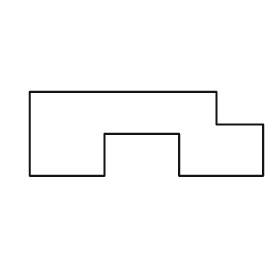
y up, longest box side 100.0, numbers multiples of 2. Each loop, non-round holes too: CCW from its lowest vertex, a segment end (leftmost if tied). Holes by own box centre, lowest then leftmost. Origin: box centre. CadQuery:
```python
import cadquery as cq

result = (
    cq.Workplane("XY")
    .moveTo(-50.0, -18.0)
    .lineTo(-18.0, -18.0)
    .lineTo(-18.0, 0.0)
    .lineTo(14.0, 0.0)
    .lineTo(14.0, -18.0)
    .lineTo(50.0, -18.0)
    .lineTo(50.0, 4.0)
    .lineTo(30.0, 4.0)
    .lineTo(30.0, 18.0)
    .lineTo(-50.0, 18.0)
    .close()
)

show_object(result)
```